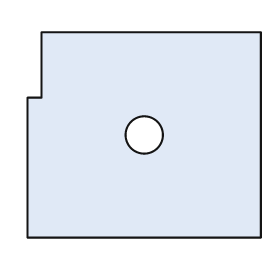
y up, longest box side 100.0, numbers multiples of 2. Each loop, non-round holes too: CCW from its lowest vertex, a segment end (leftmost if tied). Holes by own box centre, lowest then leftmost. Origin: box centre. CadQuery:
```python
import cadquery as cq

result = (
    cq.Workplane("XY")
    .moveTo(-50.0, -44.0)
    .lineTo(50.0, -44.0)
    .lineTo(50.0, 44.0)
    .lineTo(-44.0, 44.0)
    .lineTo(-44.0, 16.0)
    .lineTo(-50.0, 16.0)
    .close()
    .moveTo(0.0, 0.0)
    .circle(8.0)
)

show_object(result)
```